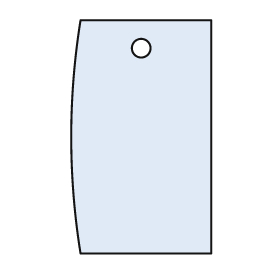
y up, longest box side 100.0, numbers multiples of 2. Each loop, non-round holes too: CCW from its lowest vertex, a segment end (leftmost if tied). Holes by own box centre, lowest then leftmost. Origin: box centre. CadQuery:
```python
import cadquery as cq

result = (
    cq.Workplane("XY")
    .moveTo(-26.0, -50.0)
    .lineTo(30.0, -50.0)
    .lineTo(30.0, 50.0)
    .lineTo(-26.0, 50.0)
    .threePointArc((-30.0, 0.0), (-26.0, -50.0))
    .close()
    .moveTo(0.0, 38.0)
    .circle(4.0)
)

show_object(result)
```